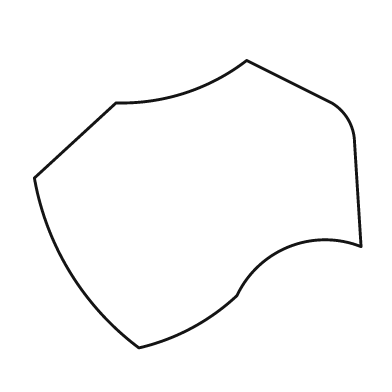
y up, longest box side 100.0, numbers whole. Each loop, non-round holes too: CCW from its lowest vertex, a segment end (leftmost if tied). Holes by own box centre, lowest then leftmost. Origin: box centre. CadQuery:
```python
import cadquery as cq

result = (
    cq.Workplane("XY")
    .moveTo(-18.0, -44.0)
    .threePointArc((-2.0, -38.0), (12.0, -28.0))
    .threePointArc((28.0, -13.0), (50.0, -13.0))
    .lineTo(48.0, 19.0)
    .threePointArc((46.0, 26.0), (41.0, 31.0))
    .lineTo(15.0, 44.0)
    .threePointArc((-4.0, 34.0), (-25.0, 31.0))
    .lineTo(-50.0, 8.0)
    .threePointArc((-39.0, -21.0), (-18.0, -44.0))
    .close()
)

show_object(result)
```